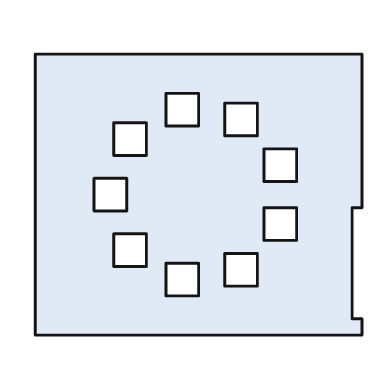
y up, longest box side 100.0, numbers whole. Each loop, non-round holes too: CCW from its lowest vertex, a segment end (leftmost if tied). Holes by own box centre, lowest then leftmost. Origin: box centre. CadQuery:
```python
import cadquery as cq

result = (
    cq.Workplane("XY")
    .moveTo(-50.0, -43.0)
    .lineTo(50.0, -43.0)
    .lineTo(50.0, -38.0)
    .lineTo(47.0, -38.0)
    .lineTo(47.0, -4.0)
    .lineTo(50.0, -4.0)
    .lineTo(50.0, 43.0)
    .lineTo(-50.0, 43.0)
    .close()
    .moveTo(-10.0, -31.0)
    .lineTo(0.0, -31.0)
    .lineTo(0.0, -21.0)
    .lineTo(-10.0, -21.0)
    .close()
    .moveTo(8.0, -28.0)
    .lineTo(18.0, -28.0)
    .lineTo(18.0, -18.0)
    .lineTo(8.0, -18.0)
    .close()
    .moveTo(-26.0, -22.0)
    .lineTo(-16.0, -22.0)
    .lineTo(-16.0, -12.0)
    .lineTo(-26.0, -12.0)
    .close()
    .moveTo(20.0, -14.0)
    .lineTo(30.0, -14.0)
    .lineTo(30.0, -4.0)
    .lineTo(20.0, -4.0)
    .close()
    .moveTo(-32.0, -5.0)
    .lineTo(-22.0, -5.0)
    .lineTo(-22.0, 5.0)
    .lineTo(-32.0, 5.0)
    .close()
    .moveTo(20.0, 4.0)
    .lineTo(30.0, 4.0)
    .lineTo(30.0, 14.0)
    .lineTo(20.0, 14.0)
    .close()
    .moveTo(-26.0, 12.0)
    .lineTo(-16.0, 12.0)
    .lineTo(-16.0, 22.0)
    .lineTo(-26.0, 22.0)
    .close()
    .moveTo(8.0, 18.0)
    .lineTo(18.0, 18.0)
    .lineTo(18.0, 28.0)
    .lineTo(8.0, 28.0)
    .close()
    .moveTo(-10.0, 21.0)
    .lineTo(0.0, 21.0)
    .lineTo(0.0, 31.0)
    .lineTo(-10.0, 31.0)
    .close()
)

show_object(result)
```